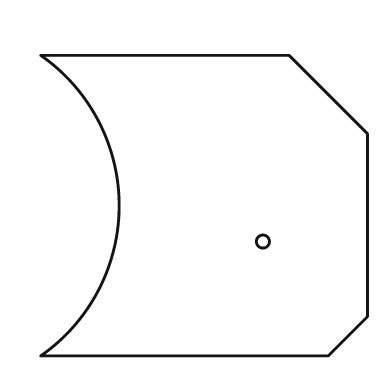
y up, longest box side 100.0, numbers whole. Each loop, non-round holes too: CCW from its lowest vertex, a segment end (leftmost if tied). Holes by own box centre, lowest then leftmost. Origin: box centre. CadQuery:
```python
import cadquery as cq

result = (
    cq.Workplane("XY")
    .moveTo(-50.0, -46.0)
    .lineTo(38.0, -46.0)
    .lineTo(50.0, -34.0)
    .lineTo(50.0, 22.0)
    .lineTo(26.0, 46.0)
    .lineTo(-50.0, 46.0)
    .threePointArc((-26.0, 0.0), (-50.0, -46.0))
    .close()
    .moveTo(18.0, -11.0)
    .circle(2.0)
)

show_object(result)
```